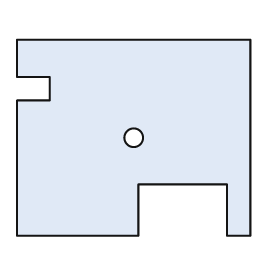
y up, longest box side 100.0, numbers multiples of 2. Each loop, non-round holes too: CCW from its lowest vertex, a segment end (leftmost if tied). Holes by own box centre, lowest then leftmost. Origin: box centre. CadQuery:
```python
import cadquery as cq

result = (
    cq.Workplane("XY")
    .moveTo(-50.0, -42.0)
    .lineTo(2.0, -42.0)
    .lineTo(2.0, -20.0)
    .lineTo(40.0, -20.0)
    .lineTo(40.0, -42.0)
    .lineTo(50.0, -42.0)
    .lineTo(50.0, 42.0)
    .lineTo(-50.0, 42.0)
    .lineTo(-50.0, 26.0)
    .lineTo(-36.0, 26.0)
    .lineTo(-36.0, 16.0)
    .lineTo(-50.0, 16.0)
    .close()
    .moveTo(0.0, 0.0)
    .circle(4.0)
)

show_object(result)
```